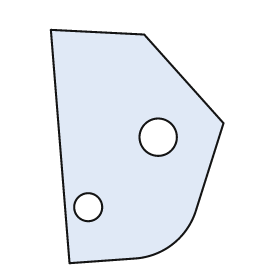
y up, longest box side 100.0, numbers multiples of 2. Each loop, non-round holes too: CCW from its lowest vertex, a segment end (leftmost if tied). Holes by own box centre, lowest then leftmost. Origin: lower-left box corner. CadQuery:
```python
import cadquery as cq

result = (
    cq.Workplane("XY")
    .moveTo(8.0, 0.0)
    .lineTo(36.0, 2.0)
    .threePointArc((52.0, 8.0), (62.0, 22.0))
    .lineTo(74.0, 60.0)
    .lineTo(40.0, 98.0)
    .lineTo(0.0, 100.0)
    .close()
    .moveTo(16.0, 24.0)
    .circle(6.0)
    .moveTo(46.0, 54.0)
    .circle(8.0)
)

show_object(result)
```